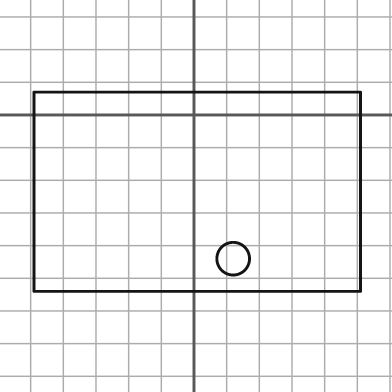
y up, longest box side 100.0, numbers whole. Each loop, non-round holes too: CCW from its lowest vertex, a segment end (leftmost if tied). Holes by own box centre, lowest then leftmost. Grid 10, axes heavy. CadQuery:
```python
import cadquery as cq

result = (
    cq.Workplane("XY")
    .moveTo(-49.0, -54.0)
    .lineTo(51.0, -54.0)
    .lineTo(51.0, 7.0)
    .lineTo(-49.0, 7.0)
    .close()
    .moveTo(12.0, -44.0)
    .circle(5.0)
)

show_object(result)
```